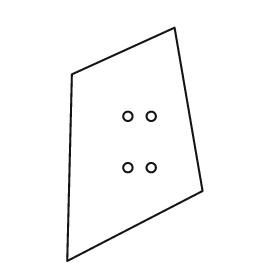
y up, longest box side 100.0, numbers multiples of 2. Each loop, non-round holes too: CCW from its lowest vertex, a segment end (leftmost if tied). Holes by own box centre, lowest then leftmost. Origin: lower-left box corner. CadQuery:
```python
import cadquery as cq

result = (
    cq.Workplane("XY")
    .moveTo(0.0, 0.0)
    .lineTo(58.0, 30.0)
    .lineTo(46.0, 100.0)
    .lineTo(2.0, 80.0)
    .close()
    .moveTo(26.0, 40.0)
    .circle(2.0)
    .moveTo(36.0, 40.0)
    .circle(2.0)
    .moveTo(26.0, 62.0)
    .circle(2.0)
    .moveTo(36.0, 62.0)
    .circle(2.0)
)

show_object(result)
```